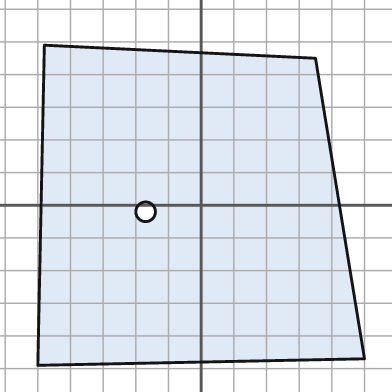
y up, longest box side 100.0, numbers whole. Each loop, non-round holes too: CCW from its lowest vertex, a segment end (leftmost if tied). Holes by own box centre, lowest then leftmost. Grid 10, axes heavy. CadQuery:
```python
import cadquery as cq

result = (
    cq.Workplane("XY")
    .moveTo(-50.0, -49.0)
    .lineTo(50.0, -47.0)
    .lineTo(35.0, 45.0)
    .lineTo(-48.0, 49.0)
    .close()
    .moveTo(-17.0, -2.0)
    .circle(3.0)
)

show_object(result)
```